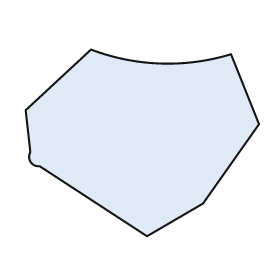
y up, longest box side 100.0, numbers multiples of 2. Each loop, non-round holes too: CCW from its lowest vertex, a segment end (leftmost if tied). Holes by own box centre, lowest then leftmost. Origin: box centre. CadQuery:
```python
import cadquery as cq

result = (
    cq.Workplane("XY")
    .moveTo(2.0, -40.0)
    .lineTo(26.0, -26.0)
    .lineTo(50.0, 8.0)
    .lineTo(38.0, 38.0)
    .threePointArc((8.0, 34.0), (-22.0, 40.0))
    .lineTo(-50.0, 14.0)
    .lineTo(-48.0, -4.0)
    .threePointArc((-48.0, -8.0), (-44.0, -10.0))
    .close()
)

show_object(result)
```